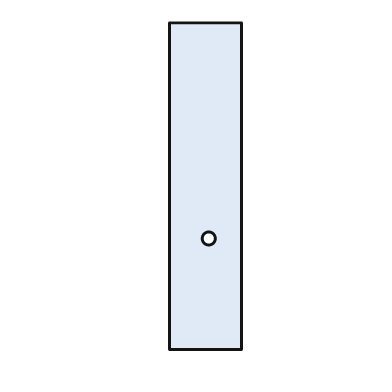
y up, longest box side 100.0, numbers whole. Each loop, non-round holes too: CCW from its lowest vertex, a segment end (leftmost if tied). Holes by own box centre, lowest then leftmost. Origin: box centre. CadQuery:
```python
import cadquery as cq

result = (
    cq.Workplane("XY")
    .moveTo(-11.0, -50.0)
    .lineTo(11.0, -50.0)
    .lineTo(11.0, 50.0)
    .lineTo(-11.0, 50.0)
    .close()
    .moveTo(1.0, -16.0)
    .circle(2.0)
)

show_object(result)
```